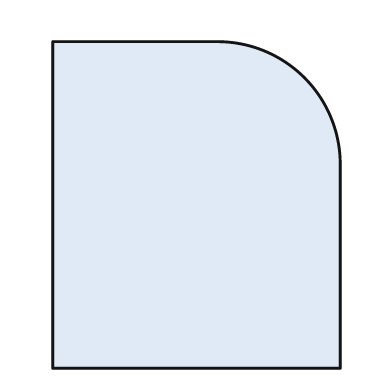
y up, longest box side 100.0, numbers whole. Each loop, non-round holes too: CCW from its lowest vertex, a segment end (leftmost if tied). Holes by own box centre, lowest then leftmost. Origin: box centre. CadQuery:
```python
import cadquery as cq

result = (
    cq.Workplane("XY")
    .moveTo(-44.0, -50.0)
    .lineTo(44.0, -50.0)
    .lineTo(44.0, 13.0)
    .threePointArc((33.0, 39.0), (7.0, 50.0))
    .lineTo(-44.0, 50.0)
    .close()
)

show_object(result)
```